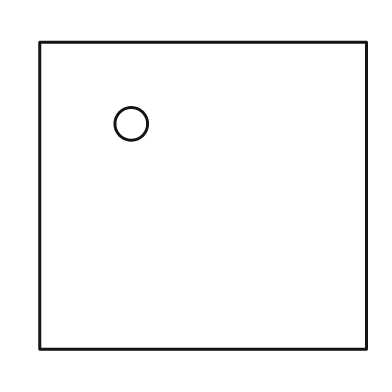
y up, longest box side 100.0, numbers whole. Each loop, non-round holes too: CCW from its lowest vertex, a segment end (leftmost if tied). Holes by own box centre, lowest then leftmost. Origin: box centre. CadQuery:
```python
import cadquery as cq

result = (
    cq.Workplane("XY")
    .moveTo(-50.0, -47.0)
    .lineTo(50.0, -47.0)
    .lineTo(50.0, 47.0)
    .lineTo(-50.0, 47.0)
    .close()
    .moveTo(-22.0, 22.0)
    .circle(5.0)
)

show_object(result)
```